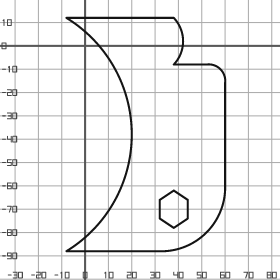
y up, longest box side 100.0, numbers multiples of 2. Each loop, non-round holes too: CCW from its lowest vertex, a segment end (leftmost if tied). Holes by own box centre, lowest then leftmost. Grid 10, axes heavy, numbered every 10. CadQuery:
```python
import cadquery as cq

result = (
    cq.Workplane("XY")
    .moveTo(-8.0, -88.0)
    .lineTo(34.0, -88.0)
    .threePointArc((52.0, -80.0), (60.0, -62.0))
    .lineTo(60.0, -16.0)
    .threePointArc((58.0, -10.0), (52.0, -8.0))
    .lineTo(38.0, -8.0)
    .threePointArc((42.0, 2.0), (38.0, 12.0))
    .lineTo(-8.0, 12.0)
    .threePointArc((20.0, -38.0), (-8.0, -88.0))
    .close()
    .moveTo(38.0, -78.0)
    .lineTo(44.0, -74.0)
    .lineTo(44.0, -66.0)
    .lineTo(38.0, -62.0)
    .lineTo(32.0, -66.0)
    .lineTo(32.0, -74.0)
    .close()
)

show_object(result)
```